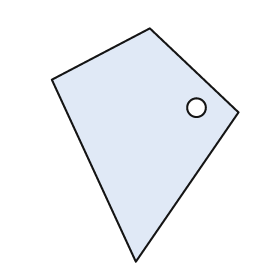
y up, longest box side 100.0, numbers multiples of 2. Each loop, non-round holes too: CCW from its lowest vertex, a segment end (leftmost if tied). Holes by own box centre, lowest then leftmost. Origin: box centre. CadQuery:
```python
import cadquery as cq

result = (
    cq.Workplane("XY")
    .moveTo(-4.0, -50.0)
    .lineTo(40.0, 14.0)
    .lineTo(2.0, 50.0)
    .lineTo(-40.0, 28.0)
    .close()
    .moveTo(22.0, 16.0)
    .circle(4.0)
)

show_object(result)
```